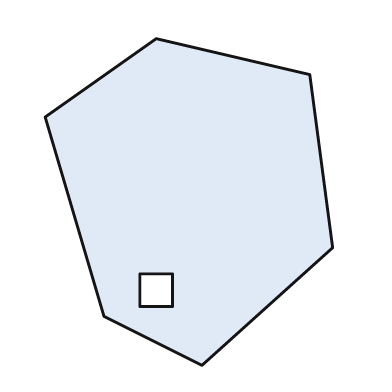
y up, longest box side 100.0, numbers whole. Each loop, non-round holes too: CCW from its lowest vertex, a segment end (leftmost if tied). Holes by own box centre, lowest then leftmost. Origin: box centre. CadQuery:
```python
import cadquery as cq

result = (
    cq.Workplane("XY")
    .moveTo(4.0, -50.0)
    .lineTo(44.0, -14.0)
    .lineTo(37.0, 39.0)
    .lineTo(-10.0, 50.0)
    .lineTo(-44.0, 26.0)
    .lineTo(-26.0, -35.0)
    .close()
    .moveTo(-15.0, -32.0)
    .lineTo(-5.0, -32.0)
    .lineTo(-5.0, -22.0)
    .lineTo(-15.0, -22.0)
    .close()
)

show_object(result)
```